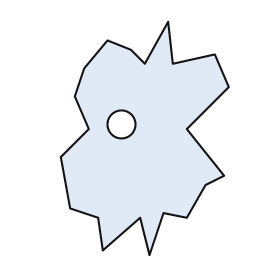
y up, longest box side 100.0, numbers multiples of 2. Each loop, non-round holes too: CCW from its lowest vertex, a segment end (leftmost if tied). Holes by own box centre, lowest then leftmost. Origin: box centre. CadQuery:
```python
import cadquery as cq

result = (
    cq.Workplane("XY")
    .moveTo(2.0, -50.0)
    .lineTo(8.0, -32.0)
    .lineTo(18.0, -34.0)
    .lineTo(26.0, -20.0)
    .lineTo(34.0, -16.0)
    .lineTo(18.0, 4.0)
    .lineTo(36.0, 22.0)
    .lineTo(30.0, 36.0)
    .lineTo(12.0, 32.0)
    .lineTo(10.0, 50.0)
    .lineTo(0.0, 32.0)
    .lineTo(-6.0, 38.0)
    .lineTo(-16.0, 42.0)
    .lineTo(-26.0, 30.0)
    .lineTo(-30.0, 18.0)
    .lineTo(-24.0, 4.0)
    .lineTo(-36.0, -8.0)
    .lineTo(-32.0, -30.0)
    .lineTo(-20.0, -34.0)
    .lineTo(-18.0, -48.0)
    .lineTo(-2.0, -34.0)
    .close()
    .moveTo(-10.0, 6.0)
    .circle(6.0)
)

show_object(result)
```